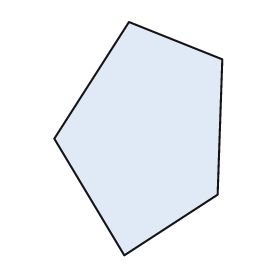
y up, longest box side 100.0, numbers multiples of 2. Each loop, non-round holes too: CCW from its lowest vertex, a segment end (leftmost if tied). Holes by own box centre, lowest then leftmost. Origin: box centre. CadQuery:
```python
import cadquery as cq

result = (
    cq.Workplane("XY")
    .moveTo(-6.0, -50.0)
    .lineTo(34.0, -24.0)
    .lineTo(36.0, 34.0)
    .lineTo(-4.0, 50.0)
    .lineTo(-36.0, 0.0)
    .close()
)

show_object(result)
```